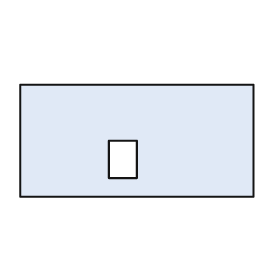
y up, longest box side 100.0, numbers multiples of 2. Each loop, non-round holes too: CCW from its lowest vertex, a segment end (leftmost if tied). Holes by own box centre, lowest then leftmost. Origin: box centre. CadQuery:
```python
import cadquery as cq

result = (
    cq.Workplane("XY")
    .moveTo(-50.0, -24.0)
    .lineTo(50.0, -24.0)
    .lineTo(50.0, 24.0)
    .lineTo(-50.0, 24.0)
    .close()
    .moveTo(-12.0, -16.0)
    .lineTo(0.0, -16.0)
    .lineTo(0.0, 0.0)
    .lineTo(-12.0, 0.0)
    .close()
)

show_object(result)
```